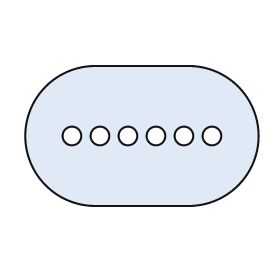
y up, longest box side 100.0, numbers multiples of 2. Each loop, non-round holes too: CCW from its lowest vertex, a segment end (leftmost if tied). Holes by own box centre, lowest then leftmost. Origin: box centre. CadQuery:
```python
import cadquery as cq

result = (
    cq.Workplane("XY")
    .moveTo(-20.0, -30.0)
    .lineTo(20.0, -30.0)
    .threePointArc((50.0, 0.0), (20.0, 30.0))
    .lineTo(-20.0, 30.0)
    .threePointArc((-50.0, 0.0), (-20.0, -30.0))
    .close()
    .moveTo(-30.0, 0.0)
    .circle(4.0)
    .moveTo(-18.0, 0.0)
    .circle(4.0)
    .moveTo(-6.0, 0.0)
    .circle(4.0)
    .moveTo(6.0, 0.0)
    .circle(4.0)
    .moveTo(18.0, 0.0)
    .circle(4.0)
    .moveTo(30.0, 0.0)
    .circle(4.0)
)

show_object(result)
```